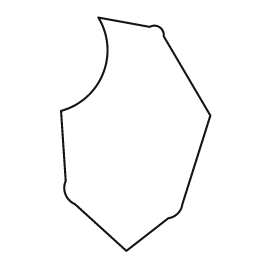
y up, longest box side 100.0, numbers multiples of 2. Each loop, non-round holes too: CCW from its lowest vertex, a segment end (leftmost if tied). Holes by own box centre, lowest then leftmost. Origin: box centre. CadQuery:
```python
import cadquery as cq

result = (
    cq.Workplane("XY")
    .moveTo(-4.0, -50.0)
    .lineTo(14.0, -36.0)
    .threePointArc((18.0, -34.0), (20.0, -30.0))
    .lineTo(32.0, 8.0)
    .lineTo(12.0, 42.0)
    .threePointArc((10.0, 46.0), (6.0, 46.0))
    .lineTo(-16.0, 50.0)
    .threePointArc((-14.0, 26.0), (-32.0, 10.0))
    .lineTo(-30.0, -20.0)
    .threePointArc((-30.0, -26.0), (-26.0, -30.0))
    .close()
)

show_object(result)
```